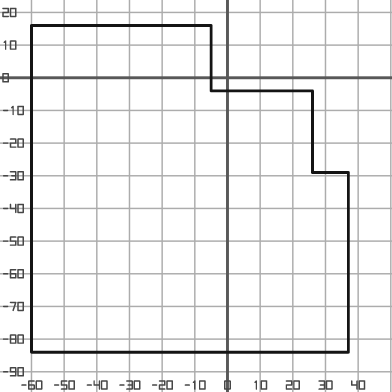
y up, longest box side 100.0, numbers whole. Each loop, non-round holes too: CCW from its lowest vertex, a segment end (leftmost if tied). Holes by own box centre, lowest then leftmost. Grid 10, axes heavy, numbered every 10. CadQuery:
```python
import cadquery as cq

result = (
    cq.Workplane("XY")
    .moveTo(-60.0, -84.0)
    .lineTo(37.0, -84.0)
    .lineTo(37.0, -29.0)
    .lineTo(26.0, -29.0)
    .lineTo(26.0, -4.0)
    .lineTo(-5.0, -4.0)
    .lineTo(-5.0, 16.0)
    .lineTo(-60.0, 16.0)
    .close()
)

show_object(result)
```